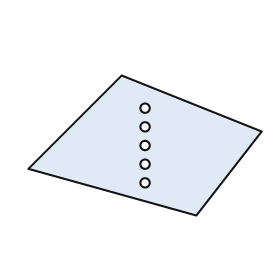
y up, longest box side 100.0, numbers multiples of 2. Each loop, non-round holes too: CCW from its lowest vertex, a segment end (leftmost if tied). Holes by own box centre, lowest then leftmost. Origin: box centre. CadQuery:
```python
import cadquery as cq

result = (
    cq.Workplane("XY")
    .moveTo(22.0, -30.0)
    .lineTo(50.0, 6.0)
    .lineTo(-10.0, 30.0)
    .lineTo(-50.0, -10.0)
    .close()
    .moveTo(0.0, -16.0)
    .circle(2.0)
    .moveTo(0.0, -8.0)
    .circle(2.0)
    .moveTo(0.0, 0.0)
    .circle(2.0)
    .moveTo(0.0, 8.0)
    .circle(2.0)
    .moveTo(0.0, 16.0)
    .circle(2.0)
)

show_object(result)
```